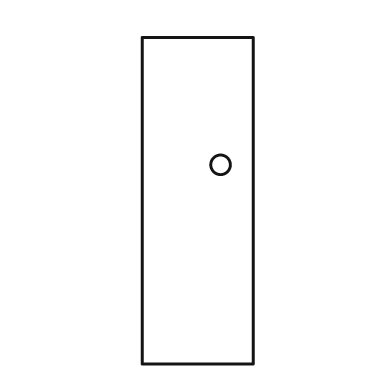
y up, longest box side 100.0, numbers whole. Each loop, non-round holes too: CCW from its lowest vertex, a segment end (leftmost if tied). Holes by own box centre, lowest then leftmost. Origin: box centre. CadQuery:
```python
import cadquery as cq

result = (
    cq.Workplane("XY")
    .moveTo(-17.0, -50.0)
    .lineTo(17.0, -50.0)
    .lineTo(17.0, 50.0)
    .lineTo(-17.0, 50.0)
    .close()
    .moveTo(7.0, 11.0)
    .circle(3.0)
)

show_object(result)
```